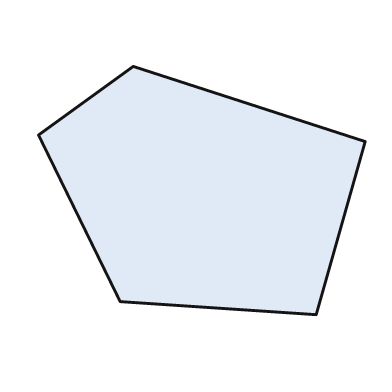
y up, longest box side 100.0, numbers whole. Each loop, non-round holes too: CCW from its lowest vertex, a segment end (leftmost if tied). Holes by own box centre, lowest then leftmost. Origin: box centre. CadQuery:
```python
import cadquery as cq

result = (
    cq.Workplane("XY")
    .moveTo(35.0, -38.0)
    .lineTo(50.0, 15.0)
    .lineTo(-21.0, 38.0)
    .lineTo(-50.0, 17.0)
    .lineTo(-25.0, -34.0)
    .close()
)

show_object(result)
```